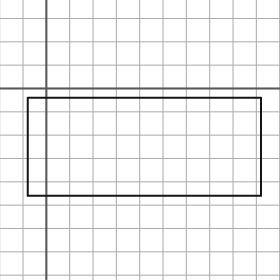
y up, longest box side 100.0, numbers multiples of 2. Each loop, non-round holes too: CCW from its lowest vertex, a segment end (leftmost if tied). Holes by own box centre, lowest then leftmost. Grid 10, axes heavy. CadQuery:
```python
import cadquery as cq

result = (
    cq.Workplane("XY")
    .moveTo(-8.0, -46.0)
    .lineTo(92.0, -46.0)
    .lineTo(92.0, -4.0)
    .lineTo(-8.0, -4.0)
    .close()
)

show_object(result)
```